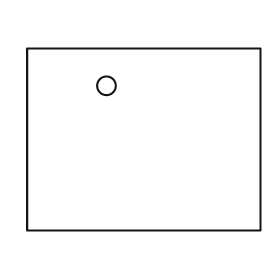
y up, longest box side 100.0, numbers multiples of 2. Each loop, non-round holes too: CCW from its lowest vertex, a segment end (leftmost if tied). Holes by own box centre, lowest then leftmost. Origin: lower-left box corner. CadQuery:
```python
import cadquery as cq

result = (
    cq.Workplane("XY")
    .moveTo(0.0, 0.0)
    .lineTo(100.0, 0.0)
    .lineTo(100.0, 78.0)
    .lineTo(0.0, 78.0)
    .close()
    .moveTo(34.0, 62.0)
    .circle(4.0)
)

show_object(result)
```